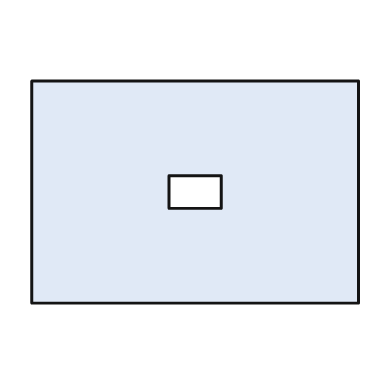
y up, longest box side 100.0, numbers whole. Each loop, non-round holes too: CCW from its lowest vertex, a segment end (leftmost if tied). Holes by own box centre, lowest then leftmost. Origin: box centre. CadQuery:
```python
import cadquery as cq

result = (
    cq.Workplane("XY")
    .moveTo(-50.0, -34.0)
    .lineTo(50.0, -34.0)
    .lineTo(50.0, 34.0)
    .lineTo(-50.0, 34.0)
    .close()
    .moveTo(-8.0, -5.0)
    .lineTo(8.0, -5.0)
    .lineTo(8.0, 5.0)
    .lineTo(-8.0, 5.0)
    .close()
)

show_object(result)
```